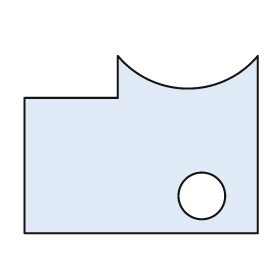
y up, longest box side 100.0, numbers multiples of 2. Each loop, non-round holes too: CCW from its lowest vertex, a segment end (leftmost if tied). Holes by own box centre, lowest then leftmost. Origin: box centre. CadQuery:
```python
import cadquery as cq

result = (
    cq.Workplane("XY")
    .moveTo(-50.0, -38.0)
    .lineTo(50.0, -38.0)
    .lineTo(50.0, 38.0)
    .threePointArc((20.0, 24.0), (-10.0, 38.0))
    .lineTo(-10.0, 20.0)
    .lineTo(-50.0, 20.0)
    .close()
    .moveTo(26.0, -22.0)
    .circle(10.0)
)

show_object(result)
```